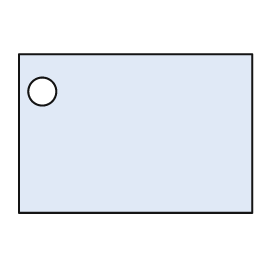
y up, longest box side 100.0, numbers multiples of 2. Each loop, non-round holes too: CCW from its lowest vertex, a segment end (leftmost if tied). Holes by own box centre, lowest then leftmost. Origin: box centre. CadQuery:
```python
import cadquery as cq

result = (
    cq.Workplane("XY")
    .moveTo(-50.0, -34.0)
    .lineTo(50.0, -34.0)
    .lineTo(50.0, 34.0)
    .lineTo(-50.0, 34.0)
    .close()
    .moveTo(-40.0, 18.0)
    .circle(6.0)
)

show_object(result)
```